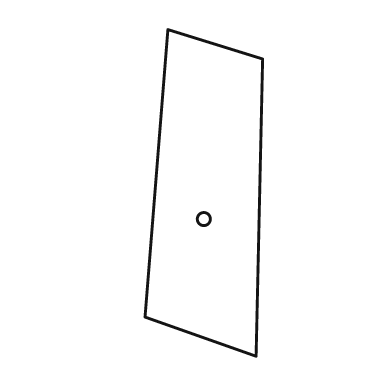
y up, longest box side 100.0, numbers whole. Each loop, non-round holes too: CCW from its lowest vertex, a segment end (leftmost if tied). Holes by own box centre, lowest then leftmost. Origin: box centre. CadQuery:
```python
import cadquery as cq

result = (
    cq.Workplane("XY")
    .moveTo(16.0, -50.0)
    .lineTo(18.0, 41.0)
    .lineTo(-11.0, 50.0)
    .lineTo(-18.0, -38.0)
    .close()
    .moveTo(0.0, -8.0)
    .circle(2.0)
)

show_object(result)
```